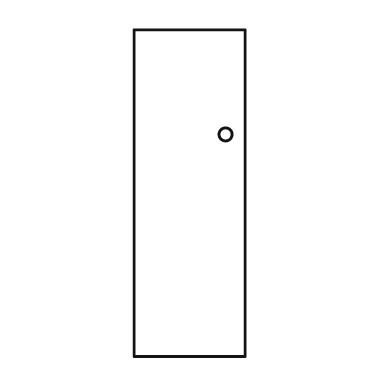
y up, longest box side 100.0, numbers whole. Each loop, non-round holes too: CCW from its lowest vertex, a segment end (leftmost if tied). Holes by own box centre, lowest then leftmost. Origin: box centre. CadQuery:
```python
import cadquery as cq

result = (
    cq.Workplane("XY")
    .moveTo(-17.0, -50.0)
    .lineTo(17.0, -50.0)
    .lineTo(17.0, 50.0)
    .lineTo(-17.0, 50.0)
    .close()
    .moveTo(11.0, 18.0)
    .circle(2.0)
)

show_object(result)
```